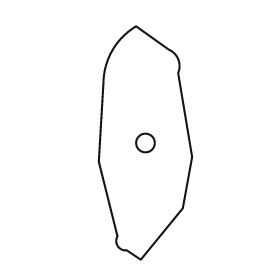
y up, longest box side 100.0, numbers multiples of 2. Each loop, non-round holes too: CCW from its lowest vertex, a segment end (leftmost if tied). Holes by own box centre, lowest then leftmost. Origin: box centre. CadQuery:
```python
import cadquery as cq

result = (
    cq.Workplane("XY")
    .moveTo(-2.0, -50.0)
    .lineTo(16.0, -28.0)
    .lineTo(20.0, -6.0)
    .lineTo(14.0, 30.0)
    .threePointArc((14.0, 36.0), (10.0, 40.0))
    .lineTo(-4.0, 50.0)
    .threePointArc((-14.0, 40.0), (-18.0, 26.0))
    .lineTo(-20.0, -8.0)
    .lineTo(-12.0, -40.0)
    .threePointArc((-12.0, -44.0), (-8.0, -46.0))
    .close()
    .moveTo(0.0, 0.0)
    .circle(4.0)
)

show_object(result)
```